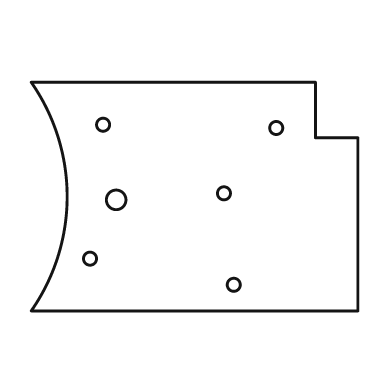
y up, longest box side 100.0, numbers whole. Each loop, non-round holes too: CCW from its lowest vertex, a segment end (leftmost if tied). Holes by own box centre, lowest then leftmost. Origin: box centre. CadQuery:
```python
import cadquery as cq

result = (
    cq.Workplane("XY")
    .moveTo(-50.0, -35.0)
    .lineTo(50.0, -35.0)
    .lineTo(50.0, 18.0)
    .lineTo(37.0, 18.0)
    .lineTo(37.0, 35.0)
    .lineTo(-50.0, 35.0)
    .threePointArc((-39.0, 0.0), (-50.0, -35.0))
    .close()
    .moveTo(12.0, -27.0)
    .circle(2.0)
    .moveTo(-32.0, -19.0)
    .circle(2.0)
    .moveTo(-24.0, -1.0)
    .circle(3.0)
    .moveTo(9.0, 1.0)
    .circle(2.0)
    .moveTo(25.0, 21.0)
    .circle(2.0)
    .moveTo(-28.0, 22.0)
    .circle(2.0)
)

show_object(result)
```